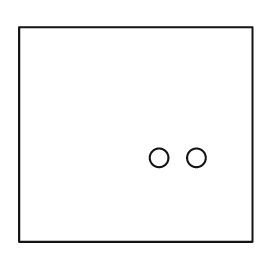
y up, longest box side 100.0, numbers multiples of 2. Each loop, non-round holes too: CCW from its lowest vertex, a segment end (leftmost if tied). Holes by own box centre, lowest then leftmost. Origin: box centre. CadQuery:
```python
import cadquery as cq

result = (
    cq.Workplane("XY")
    .moveTo(-50.0, -46.0)
    .lineTo(50.0, -46.0)
    .lineTo(50.0, 46.0)
    .lineTo(-50.0, 46.0)
    .close()
    .moveTo(10.0, -10.0)
    .circle(4.0)
    .moveTo(26.0, -10.0)
    .circle(4.0)
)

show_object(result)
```